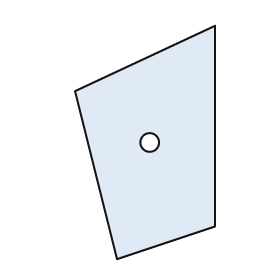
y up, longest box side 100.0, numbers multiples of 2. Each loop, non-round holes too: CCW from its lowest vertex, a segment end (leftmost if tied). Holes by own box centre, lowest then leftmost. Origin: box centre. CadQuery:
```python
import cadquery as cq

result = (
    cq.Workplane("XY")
    .moveTo(-12.0, -50.0)
    .lineTo(30.0, -36.0)
    .lineTo(30.0, 50.0)
    .lineTo(-30.0, 22.0)
    .close()
    .moveTo(2.0, 0.0)
    .circle(4.0)
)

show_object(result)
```